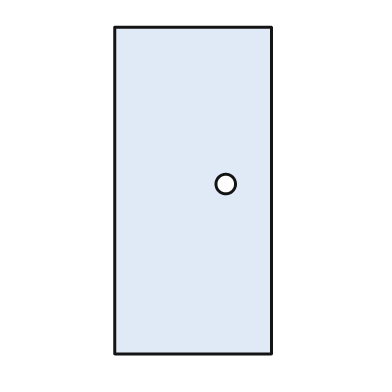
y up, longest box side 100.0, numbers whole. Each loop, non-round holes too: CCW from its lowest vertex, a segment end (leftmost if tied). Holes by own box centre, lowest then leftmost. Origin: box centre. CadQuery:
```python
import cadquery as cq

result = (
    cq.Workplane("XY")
    .moveTo(-24.0, -50.0)
    .lineTo(24.0, -50.0)
    .lineTo(24.0, 50.0)
    .lineTo(-24.0, 50.0)
    .close()
    .moveTo(10.0, 2.0)
    .circle(3.0)
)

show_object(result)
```